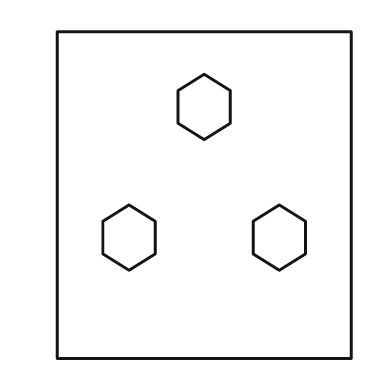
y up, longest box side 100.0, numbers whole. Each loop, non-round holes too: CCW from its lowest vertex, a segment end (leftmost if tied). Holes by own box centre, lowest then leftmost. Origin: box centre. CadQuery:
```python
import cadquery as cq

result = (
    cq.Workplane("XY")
    .moveTo(-45.0, -50.0)
    .lineTo(45.0, -50.0)
    .lineTo(45.0, 50.0)
    .lineTo(-45.0, 50.0)
    .close()
    .moveTo(-23.0, -23.0)
    .lineTo(-15.0, -18.0)
    .lineTo(-15.0, -8.0)
    .lineTo(-23.0, -3.0)
    .lineTo(-31.0, -8.0)
    .lineTo(-31.0, -18.0)
    .close()
    .moveTo(23.0, -23.0)
    .lineTo(31.0, -18.0)
    .lineTo(31.0, -8.0)
    .lineTo(23.0, -3.0)
    .lineTo(15.0, -8.0)
    .lineTo(15.0, -18.0)
    .close()
    .moveTo(0.0, 17.0)
    .lineTo(8.0, 22.0)
    .lineTo(8.0, 32.0)
    .lineTo(0.0, 37.0)
    .lineTo(-8.0, 32.0)
    .lineTo(-8.0, 22.0)
    .close()
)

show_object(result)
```